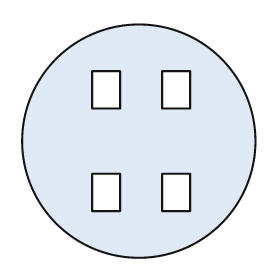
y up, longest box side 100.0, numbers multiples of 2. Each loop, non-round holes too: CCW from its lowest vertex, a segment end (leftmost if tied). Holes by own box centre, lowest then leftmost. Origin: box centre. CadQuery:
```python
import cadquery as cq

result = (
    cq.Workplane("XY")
    .moveTo(0.0, 0.0)
    .circle(50.0)
    .moveTo(-20.0, -30.0)
    .lineTo(-8.0, -30.0)
    .lineTo(-8.0, -14.0)
    .lineTo(-20.0, -14.0)
    .close()
    .moveTo(10.0, -30.0)
    .lineTo(22.0, -30.0)
    .lineTo(22.0, -14.0)
    .lineTo(10.0, -14.0)
    .close()
    .moveTo(-20.0, 14.0)
    .lineTo(-8.0, 14.0)
    .lineTo(-8.0, 30.0)
    .lineTo(-20.0, 30.0)
    .close()
    .moveTo(10.0, 14.0)
    .lineTo(22.0, 14.0)
    .lineTo(22.0, 30.0)
    .lineTo(10.0, 30.0)
    .close()
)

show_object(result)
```